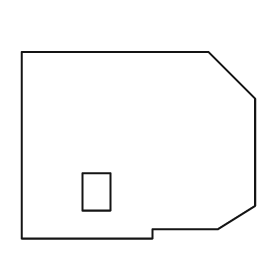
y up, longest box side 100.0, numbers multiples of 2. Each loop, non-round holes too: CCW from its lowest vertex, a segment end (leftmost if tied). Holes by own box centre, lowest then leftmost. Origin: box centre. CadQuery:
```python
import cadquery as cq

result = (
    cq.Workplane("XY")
    .moveTo(-50.0, -40.0)
    .lineTo(6.0, -40.0)
    .lineTo(6.0, -36.0)
    .lineTo(34.0, -36.0)
    .lineTo(50.0, -26.0)
    .lineTo(50.0, 20.0)
    .lineTo(30.0, 40.0)
    .lineTo(-50.0, 40.0)
    .close()
    .moveTo(-24.0, -28.0)
    .lineTo(-12.0, -28.0)
    .lineTo(-12.0, -12.0)
    .lineTo(-24.0, -12.0)
    .close()
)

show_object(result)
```